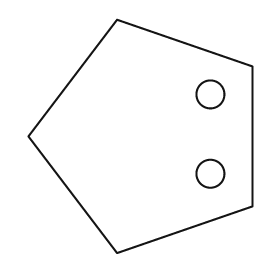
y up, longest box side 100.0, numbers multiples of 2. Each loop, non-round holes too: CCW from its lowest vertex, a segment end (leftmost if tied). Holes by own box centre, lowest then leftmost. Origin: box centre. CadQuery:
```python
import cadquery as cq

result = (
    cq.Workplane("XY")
    .moveTo(-10.0, -50.0)
    .lineTo(48.0, -30.0)
    .lineTo(48.0, 30.0)
    .lineTo(-10.0, 50.0)
    .lineTo(-48.0, 0.0)
    .close()
    .moveTo(30.0, -16.0)
    .circle(6.0)
    .moveTo(30.0, 18.0)
    .circle(6.0)
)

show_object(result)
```